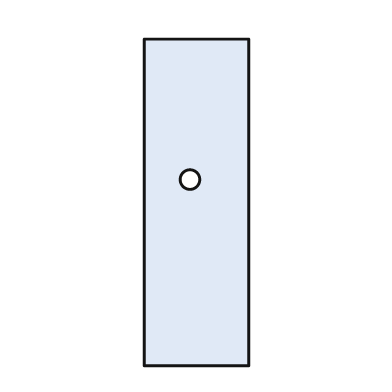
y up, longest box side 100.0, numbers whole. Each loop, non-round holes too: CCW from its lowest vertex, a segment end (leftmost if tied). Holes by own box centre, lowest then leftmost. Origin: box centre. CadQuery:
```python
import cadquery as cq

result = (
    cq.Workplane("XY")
    .moveTo(-16.0, -50.0)
    .lineTo(16.0, -50.0)
    .lineTo(16.0, 50.0)
    .lineTo(-16.0, 50.0)
    .close()
    .moveTo(-2.0, 7.0)
    .circle(3.0)
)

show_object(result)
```